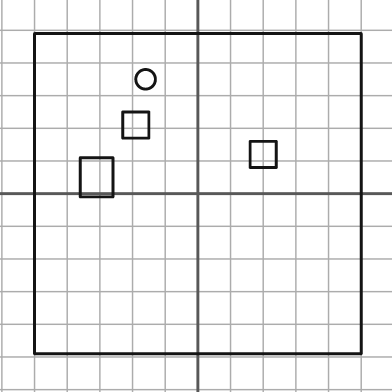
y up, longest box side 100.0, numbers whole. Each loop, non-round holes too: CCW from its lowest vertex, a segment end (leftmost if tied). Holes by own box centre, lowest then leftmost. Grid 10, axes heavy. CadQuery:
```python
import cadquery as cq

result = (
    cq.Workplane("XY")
    .moveTo(-50.0, -49.0)
    .lineTo(50.0, -49.0)
    .lineTo(50.0, 49.0)
    .lineTo(-50.0, 49.0)
    .close()
    .moveTo(-36.0, -1.0)
    .lineTo(-26.0, -1.0)
    .lineTo(-26.0, 11.0)
    .lineTo(-36.0, 11.0)
    .close()
    .moveTo(16.0, 8.0)
    .lineTo(24.0, 8.0)
    .lineTo(24.0, 16.0)
    .lineTo(16.0, 16.0)
    .close()
    .moveTo(-23.0, 17.0)
    .lineTo(-15.0, 17.0)
    .lineTo(-15.0, 25.0)
    .lineTo(-23.0, 25.0)
    .close()
    .moveTo(-16.0, 35.0)
    .circle(3.0)
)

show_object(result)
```